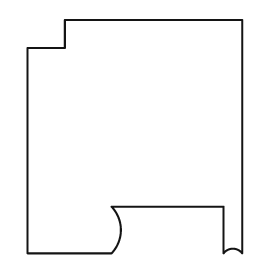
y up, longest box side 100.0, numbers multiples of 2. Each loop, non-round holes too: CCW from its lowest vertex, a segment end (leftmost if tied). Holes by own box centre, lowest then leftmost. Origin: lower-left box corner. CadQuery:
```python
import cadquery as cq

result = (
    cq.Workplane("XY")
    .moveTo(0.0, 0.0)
    .lineTo(36.0, 0.0)
    .threePointArc((40.0, 10.0), (36.0, 20.0))
    .lineTo(84.0, 20.0)
    .lineTo(84.0, 0.0)
    .threePointArc((88.0, 2.0), (92.0, 0.0))
    .lineTo(92.0, 100.0)
    .lineTo(16.0, 100.0)
    .lineTo(16.0, 88.0)
    .lineTo(0.0, 88.0)
    .close()
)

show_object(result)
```